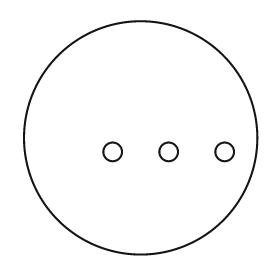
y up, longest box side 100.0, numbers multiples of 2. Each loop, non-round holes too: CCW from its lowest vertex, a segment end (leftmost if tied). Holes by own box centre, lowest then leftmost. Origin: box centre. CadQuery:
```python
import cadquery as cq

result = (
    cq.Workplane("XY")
    .moveTo(0.0, 0.0)
    .circle(50.0)
    .moveTo(-12.0, -6.0)
    .circle(4.0)
    .moveTo(12.0, -6.0)
    .circle(4.0)
    .moveTo(36.0, -6.0)
    .circle(4.0)
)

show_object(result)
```